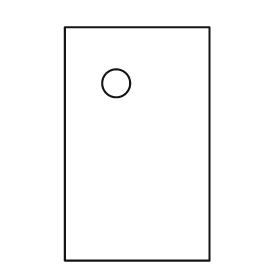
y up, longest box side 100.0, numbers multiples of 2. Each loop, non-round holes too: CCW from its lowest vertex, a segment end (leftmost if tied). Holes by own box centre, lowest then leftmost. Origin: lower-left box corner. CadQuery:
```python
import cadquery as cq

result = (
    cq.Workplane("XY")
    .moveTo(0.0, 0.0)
    .lineTo(62.0, 0.0)
    .lineTo(62.0, 100.0)
    .lineTo(0.0, 100.0)
    .close()
    .moveTo(22.0, 76.0)
    .circle(6.0)
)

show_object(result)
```